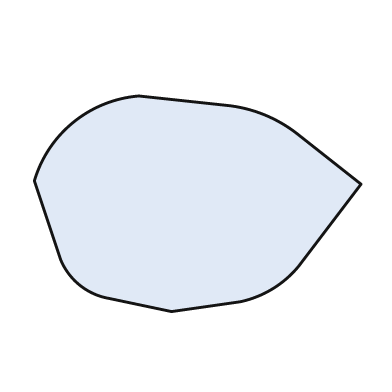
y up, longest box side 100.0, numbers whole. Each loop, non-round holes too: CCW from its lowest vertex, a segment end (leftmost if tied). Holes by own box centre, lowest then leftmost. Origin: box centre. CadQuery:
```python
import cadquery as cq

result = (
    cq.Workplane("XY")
    .moveTo(-8.0, -33.0)
    .lineTo(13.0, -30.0)
    .threePointArc((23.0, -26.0), (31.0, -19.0))
    .lineTo(50.0, 6.0)
    .lineTo(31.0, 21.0)
    .threePointArc((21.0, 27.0), (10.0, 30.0))
    .lineTo(-18.0, 33.0)
    .threePointArc((-38.0, 25.0), (-50.0, 7.0))
    .lineTo(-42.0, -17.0)
    .threePointArc((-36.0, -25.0), (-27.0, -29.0))
    .close()
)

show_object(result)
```